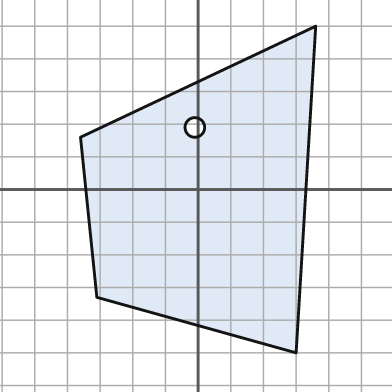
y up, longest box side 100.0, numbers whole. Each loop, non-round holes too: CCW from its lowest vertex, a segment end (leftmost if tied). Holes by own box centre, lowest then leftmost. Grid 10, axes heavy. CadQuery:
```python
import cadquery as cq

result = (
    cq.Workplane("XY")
    .moveTo(30.0, -50.0)
    .lineTo(36.0, 50.0)
    .lineTo(-36.0, 16.0)
    .lineTo(-31.0, -33.0)
    .close()
    .moveTo(-1.0, 19.0)
    .circle(3.0)
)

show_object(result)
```